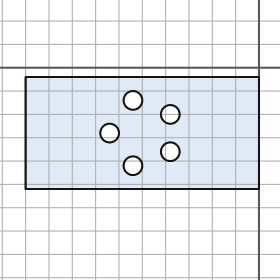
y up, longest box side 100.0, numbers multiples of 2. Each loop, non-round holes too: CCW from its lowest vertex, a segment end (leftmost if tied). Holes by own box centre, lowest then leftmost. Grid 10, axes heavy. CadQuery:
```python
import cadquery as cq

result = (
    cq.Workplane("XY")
    .moveTo(-100.0, -52.0)
    .lineTo(0.0, -52.0)
    .lineTo(0.0, -4.0)
    .lineTo(-100.0, -4.0)
    .close()
    .moveTo(-54.0, -42.0)
    .circle(4.0)
    .moveTo(-38.0, -36.0)
    .circle(4.0)
    .moveTo(-64.0, -28.0)
    .circle(4.0)
    .moveTo(-38.0, -20.0)
    .circle(4.0)
    .moveTo(-54.0, -14.0)
    .circle(4.0)
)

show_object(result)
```